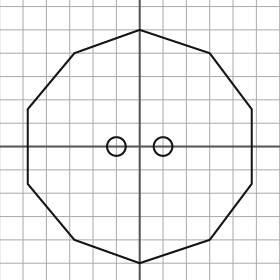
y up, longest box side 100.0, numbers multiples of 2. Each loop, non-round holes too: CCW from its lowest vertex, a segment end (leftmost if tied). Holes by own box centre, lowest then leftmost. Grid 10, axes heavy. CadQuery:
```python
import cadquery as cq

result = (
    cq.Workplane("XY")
    .moveTo(0.0, -50.0)
    .lineTo(30.0, -40.0)
    .lineTo(48.0, -16.0)
    .lineTo(48.0, 16.0)
    .lineTo(30.0, 40.0)
    .lineTo(0.0, 50.0)
    .lineTo(-28.0, 40.0)
    .lineTo(-48.0, 16.0)
    .lineTo(-48.0, -16.0)
    .lineTo(-28.0, -40.0)
    .close()
    .moveTo(-10.0, 0.0)
    .circle(4.0)
    .moveTo(10.0, 0.0)
    .circle(4.0)
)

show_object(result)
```